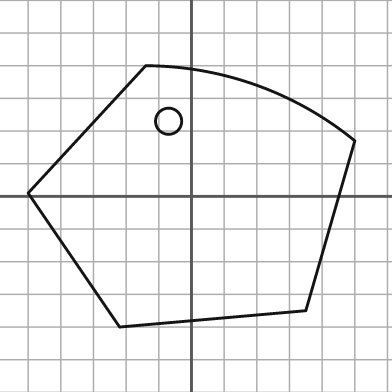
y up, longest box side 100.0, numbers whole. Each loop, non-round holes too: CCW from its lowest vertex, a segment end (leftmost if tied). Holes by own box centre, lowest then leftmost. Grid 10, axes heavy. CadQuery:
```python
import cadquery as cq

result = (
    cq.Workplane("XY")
    .moveTo(-22.0, -40.0)
    .lineTo(35.0, -35.0)
    .lineTo(50.0, 17.0)
    .threePointArc((20.0, 34.0), (-14.0, 40.0))
    .lineTo(-50.0, 1.0)
    .close()
    .moveTo(-7.0, 23.0)
    .circle(4.0)
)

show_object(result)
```